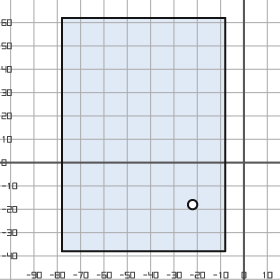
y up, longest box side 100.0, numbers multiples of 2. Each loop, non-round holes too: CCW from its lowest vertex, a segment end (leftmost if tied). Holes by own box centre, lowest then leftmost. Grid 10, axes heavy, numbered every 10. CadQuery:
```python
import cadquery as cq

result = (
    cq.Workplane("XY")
    .moveTo(-78.0, -38.0)
    .lineTo(-8.0, -38.0)
    .lineTo(-8.0, 62.0)
    .lineTo(-78.0, 62.0)
    .close()
    .moveTo(-22.0, -18.0)
    .circle(2.0)
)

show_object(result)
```